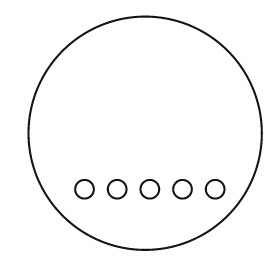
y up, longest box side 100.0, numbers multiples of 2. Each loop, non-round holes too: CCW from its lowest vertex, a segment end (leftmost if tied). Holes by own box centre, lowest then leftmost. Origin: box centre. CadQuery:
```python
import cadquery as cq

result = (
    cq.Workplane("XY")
    .moveTo(0.0, 0.0)
    .circle(50.0)
    .moveTo(-26.0, -24.0)
    .circle(4.0)
    .moveTo(-12.0, -24.0)
    .circle(4.0)
    .moveTo(2.0, -24.0)
    .circle(4.0)
    .moveTo(16.0, -24.0)
    .circle(4.0)
    .moveTo(30.0, -24.0)
    .circle(4.0)
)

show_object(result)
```